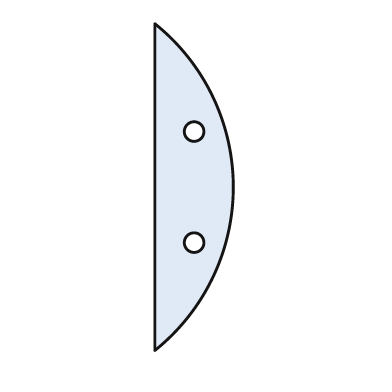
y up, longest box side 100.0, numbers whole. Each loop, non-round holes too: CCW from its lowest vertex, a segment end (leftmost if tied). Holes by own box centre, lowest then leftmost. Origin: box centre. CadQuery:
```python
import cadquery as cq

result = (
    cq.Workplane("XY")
    .moveTo(-12.0, -50.0)
    .threePointArc((12.0, 0.0), (-12.0, 50.0))
    .close()
    .moveTo(0.0, -17.0)
    .circle(3.0)
    .moveTo(0.0, 17.0)
    .circle(3.0)
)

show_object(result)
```